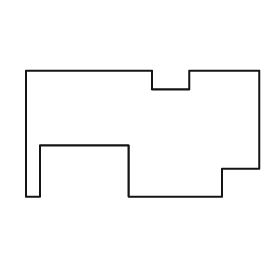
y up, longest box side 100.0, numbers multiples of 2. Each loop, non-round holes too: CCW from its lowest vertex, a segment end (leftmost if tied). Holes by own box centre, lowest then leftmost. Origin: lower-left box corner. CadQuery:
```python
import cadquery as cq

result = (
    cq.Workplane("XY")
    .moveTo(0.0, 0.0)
    .lineTo(6.0, 0.0)
    .lineTo(6.0, 22.0)
    .lineTo(44.0, 22.0)
    .lineTo(44.0, 0.0)
    .lineTo(84.0, 0.0)
    .lineTo(84.0, 12.0)
    .lineTo(100.0, 12.0)
    .lineTo(100.0, 54.0)
    .lineTo(70.0, 54.0)
    .lineTo(70.0, 46.0)
    .lineTo(54.0, 46.0)
    .lineTo(54.0, 54.0)
    .lineTo(0.0, 54.0)
    .close()
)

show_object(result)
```